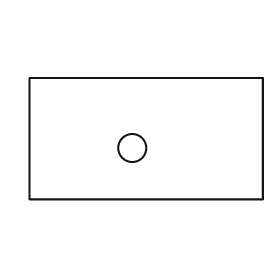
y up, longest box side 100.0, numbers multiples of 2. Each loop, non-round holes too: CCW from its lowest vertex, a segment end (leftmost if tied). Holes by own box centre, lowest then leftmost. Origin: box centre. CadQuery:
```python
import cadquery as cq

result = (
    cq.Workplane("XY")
    .moveTo(-50.0, -26.0)
    .lineTo(50.0, -26.0)
    .lineTo(50.0, 26.0)
    .lineTo(-50.0, 26.0)
    .close()
    .moveTo(-6.0, -4.0)
    .circle(6.0)
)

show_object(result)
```